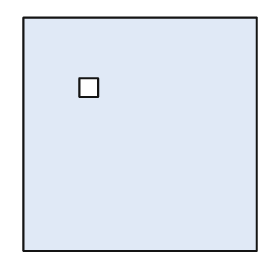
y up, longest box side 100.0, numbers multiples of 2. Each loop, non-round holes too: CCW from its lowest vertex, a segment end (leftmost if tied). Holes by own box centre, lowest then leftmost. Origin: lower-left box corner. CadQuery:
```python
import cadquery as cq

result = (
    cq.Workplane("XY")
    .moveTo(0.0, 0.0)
    .lineTo(100.0, 0.0)
    .lineTo(100.0, 100.0)
    .lineTo(0.0, 100.0)
    .close()
    .moveTo(24.0, 66.0)
    .lineTo(32.0, 66.0)
    .lineTo(32.0, 74.0)
    .lineTo(24.0, 74.0)
    .close()
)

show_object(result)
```